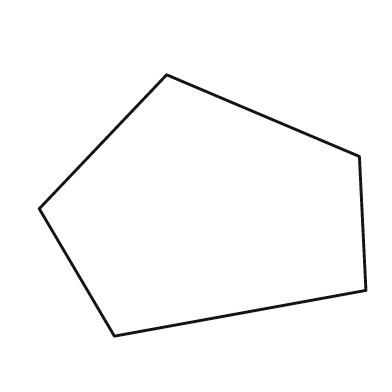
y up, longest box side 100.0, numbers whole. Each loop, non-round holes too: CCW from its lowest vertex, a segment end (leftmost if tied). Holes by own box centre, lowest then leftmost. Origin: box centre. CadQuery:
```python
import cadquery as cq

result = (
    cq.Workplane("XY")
    .moveTo(-27.0, -40.0)
    .lineTo(50.0, -26.0)
    .lineTo(48.0, 15.0)
    .lineTo(-11.0, 40.0)
    .lineTo(-50.0, -1.0)
    .close()
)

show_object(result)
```